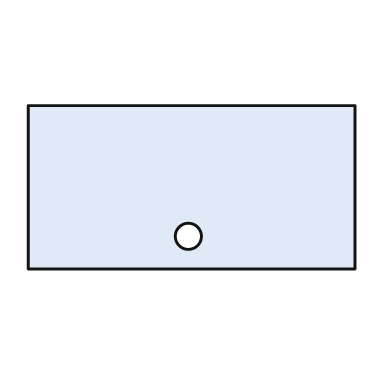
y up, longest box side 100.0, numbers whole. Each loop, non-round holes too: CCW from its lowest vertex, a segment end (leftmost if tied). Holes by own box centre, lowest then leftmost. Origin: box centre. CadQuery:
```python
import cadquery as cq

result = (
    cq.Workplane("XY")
    .moveTo(-50.0, -25.0)
    .lineTo(50.0, -25.0)
    .lineTo(50.0, 25.0)
    .lineTo(-50.0, 25.0)
    .close()
    .moveTo(-1.0, -15.0)
    .circle(4.0)
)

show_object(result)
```